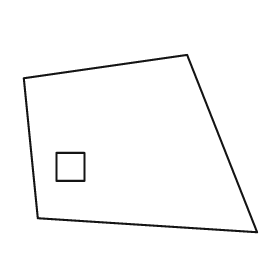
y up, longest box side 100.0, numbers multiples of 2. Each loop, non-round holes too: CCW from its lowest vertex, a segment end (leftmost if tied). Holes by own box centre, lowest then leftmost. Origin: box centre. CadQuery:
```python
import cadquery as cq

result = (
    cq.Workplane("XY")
    .moveTo(50.0, -38.0)
    .lineTo(20.0, 38.0)
    .lineTo(-50.0, 28.0)
    .lineTo(-44.0, -32.0)
    .close()
    .moveTo(-36.0, -16.0)
    .lineTo(-24.0, -16.0)
    .lineTo(-24.0, -4.0)
    .lineTo(-36.0, -4.0)
    .close()
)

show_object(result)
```